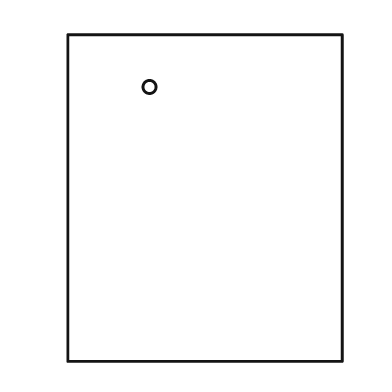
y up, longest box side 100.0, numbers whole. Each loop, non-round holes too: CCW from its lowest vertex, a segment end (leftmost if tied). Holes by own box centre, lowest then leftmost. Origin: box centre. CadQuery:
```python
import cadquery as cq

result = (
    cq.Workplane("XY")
    .moveTo(-42.0, -50.0)
    .lineTo(42.0, -50.0)
    .lineTo(42.0, 50.0)
    .lineTo(-42.0, 50.0)
    .close()
    .moveTo(-17.0, 34.0)
    .circle(2.0)
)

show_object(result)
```